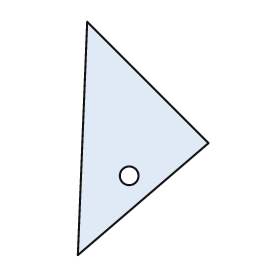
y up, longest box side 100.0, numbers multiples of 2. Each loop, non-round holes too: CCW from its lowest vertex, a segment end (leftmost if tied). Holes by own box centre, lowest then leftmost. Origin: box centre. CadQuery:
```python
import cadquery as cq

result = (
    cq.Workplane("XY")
    .moveTo(-28.0, -50.0)
    .lineTo(28.0, -2.0)
    .lineTo(-24.0, 50.0)
    .close()
    .moveTo(-6.0, -16.0)
    .circle(4.0)
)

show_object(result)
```